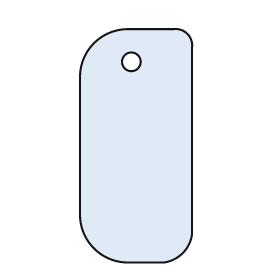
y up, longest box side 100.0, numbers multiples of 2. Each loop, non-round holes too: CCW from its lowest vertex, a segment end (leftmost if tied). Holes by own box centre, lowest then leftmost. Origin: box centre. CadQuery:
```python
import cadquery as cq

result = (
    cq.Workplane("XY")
    .moveTo(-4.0, -50.0)
    .lineTo(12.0, -50.0)
    .threePointArc((20.0, -46.0), (24.0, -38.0))
    .lineTo(24.0, 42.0)
    .threePointArc((22.0, 48.0), (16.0, 50.0))
    .lineTo(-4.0, 50.0)
    .threePointArc((-18.0, 44.0), (-24.0, 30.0))
    .lineTo(-24.0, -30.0)
    .threePointArc((-18.0, -44.0), (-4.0, -50.0))
    .close()
    .moveTo(-2.0, 36.0)
    .circle(4.0)
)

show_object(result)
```